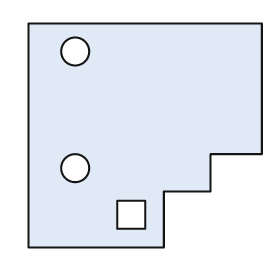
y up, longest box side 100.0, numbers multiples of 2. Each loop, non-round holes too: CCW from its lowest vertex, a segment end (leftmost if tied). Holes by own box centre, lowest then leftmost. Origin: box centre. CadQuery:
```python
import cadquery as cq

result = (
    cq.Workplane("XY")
    .moveTo(-50.0, -48.0)
    .lineTo(8.0, -48.0)
    .lineTo(8.0, -24.0)
    .lineTo(28.0, -24.0)
    .lineTo(28.0, -8.0)
    .lineTo(50.0, -8.0)
    .lineTo(50.0, 48.0)
    .lineTo(-50.0, 48.0)
    .close()
    .moveTo(-12.0, -40.0)
    .lineTo(0.0, -40.0)
    .lineTo(0.0, -28.0)
    .lineTo(-12.0, -28.0)
    .close()
    .moveTo(-30.0, -14.0)
    .circle(6.0)
    .moveTo(-30.0, 36.0)
    .circle(6.0)
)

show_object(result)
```